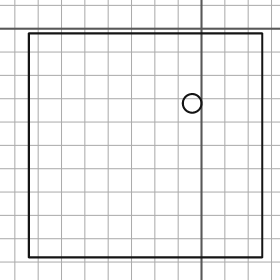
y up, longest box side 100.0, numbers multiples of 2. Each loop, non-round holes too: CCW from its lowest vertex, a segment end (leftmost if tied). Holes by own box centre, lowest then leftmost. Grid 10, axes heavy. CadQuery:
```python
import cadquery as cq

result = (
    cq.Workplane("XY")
    .moveTo(-74.0, -98.0)
    .lineTo(26.0, -98.0)
    .lineTo(26.0, -2.0)
    .lineTo(-74.0, -2.0)
    .close()
    .moveTo(-4.0, -32.0)
    .circle(4.0)
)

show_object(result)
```